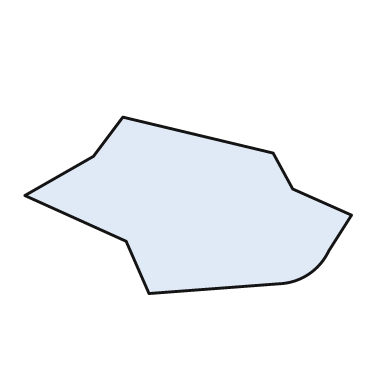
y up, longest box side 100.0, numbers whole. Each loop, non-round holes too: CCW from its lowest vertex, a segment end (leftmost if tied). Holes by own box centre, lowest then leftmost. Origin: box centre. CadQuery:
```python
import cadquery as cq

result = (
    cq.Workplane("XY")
    .moveTo(-12.0, -27.0)
    .lineTo(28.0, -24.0)
    .threePointArc((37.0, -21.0), (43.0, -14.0))
    .lineTo(50.0, -3.0)
    .lineTo(32.0, 5.0)
    .lineTo(26.0, 16.0)
    .lineTo(-20.0, 27.0)
    .lineTo(-29.0, 15.0)
    .lineTo(-50.0, 3.0)
    .lineTo(-19.0, -11.0)
    .close()
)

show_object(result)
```